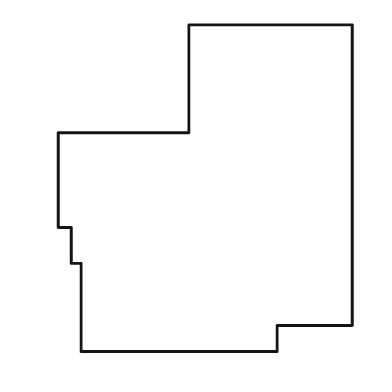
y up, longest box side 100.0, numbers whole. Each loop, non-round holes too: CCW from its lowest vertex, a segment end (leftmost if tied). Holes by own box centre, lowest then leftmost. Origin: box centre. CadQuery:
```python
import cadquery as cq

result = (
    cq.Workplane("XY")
    .moveTo(-38.0, -50.0)
    .lineTo(22.0, -50.0)
    .lineTo(22.0, -42.0)
    .lineTo(45.0, -42.0)
    .lineTo(45.0, 50.0)
    .lineTo(-5.0, 50.0)
    .lineTo(-5.0, 17.0)
    .lineTo(-45.0, 17.0)
    .lineTo(-45.0, -12.0)
    .lineTo(-41.0, -12.0)
    .lineTo(-41.0, -23.0)
    .lineTo(-38.0, -23.0)
    .close()
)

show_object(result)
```